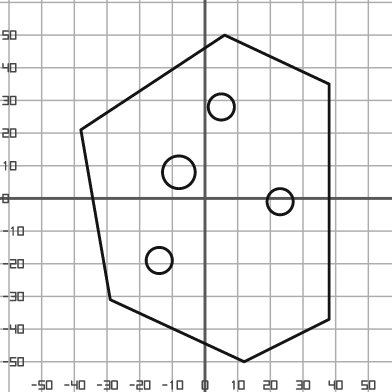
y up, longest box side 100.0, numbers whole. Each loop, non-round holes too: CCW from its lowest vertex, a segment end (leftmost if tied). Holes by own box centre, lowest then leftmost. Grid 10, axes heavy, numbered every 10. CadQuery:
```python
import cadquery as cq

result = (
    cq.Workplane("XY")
    .moveTo(12.0, -50.0)
    .lineTo(38.0, -37.0)
    .lineTo(38.0, 35.0)
    .lineTo(6.0, 50.0)
    .lineTo(-38.0, 21.0)
    .lineTo(-29.0, -31.0)
    .close()
    .moveTo(-14.0, -19.0)
    .circle(4.0)
    .moveTo(23.0, -1.0)
    .circle(4.0)
    .moveTo(-8.0, 8.0)
    .circle(5.0)
    .moveTo(5.0, 28.0)
    .circle(4.0)
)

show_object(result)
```